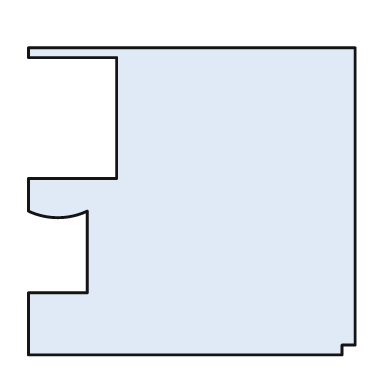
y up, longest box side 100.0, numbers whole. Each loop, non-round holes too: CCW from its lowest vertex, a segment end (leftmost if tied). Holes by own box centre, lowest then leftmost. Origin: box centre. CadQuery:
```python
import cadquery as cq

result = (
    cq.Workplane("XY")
    .moveTo(-50.0, -47.0)
    .lineTo(46.0, -47.0)
    .lineTo(46.0, -44.0)
    .lineTo(50.0, -44.0)
    .lineTo(50.0, 47.0)
    .lineTo(-50.0, 47.0)
    .lineTo(-50.0, 44.0)
    .lineTo(-23.0, 44.0)
    .lineTo(-23.0, 7.0)
    .lineTo(-50.0, 7.0)
    .lineTo(-50.0, -3.0)
    .threePointArc((-41.0, -5.0), (-32.0, -3.0))
    .lineTo(-32.0, -28.0)
    .lineTo(-50.0, -28.0)
    .close()
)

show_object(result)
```